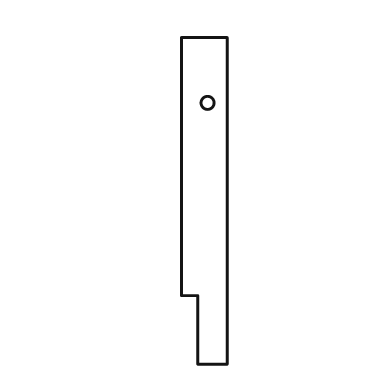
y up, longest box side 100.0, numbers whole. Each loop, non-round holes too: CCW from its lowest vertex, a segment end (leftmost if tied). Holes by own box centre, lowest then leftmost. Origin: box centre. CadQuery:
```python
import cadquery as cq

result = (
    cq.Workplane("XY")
    .moveTo(-2.0, -50.0)
    .lineTo(7.0, -50.0)
    .lineTo(7.0, 50.0)
    .lineTo(-7.0, 50.0)
    .lineTo(-7.0, -29.0)
    .lineTo(-2.0, -29.0)
    .close()
    .moveTo(1.0, 30.0)
    .circle(2.0)
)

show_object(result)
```